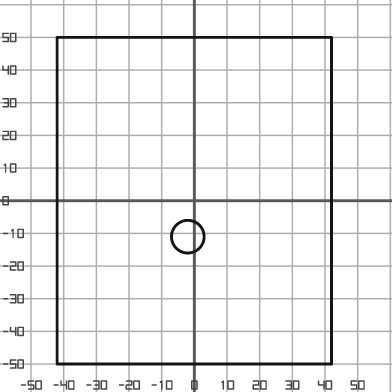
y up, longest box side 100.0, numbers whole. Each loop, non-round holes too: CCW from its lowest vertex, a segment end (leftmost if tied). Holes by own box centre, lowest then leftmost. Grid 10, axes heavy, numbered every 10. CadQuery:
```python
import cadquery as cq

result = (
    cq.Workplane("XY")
    .moveTo(-42.0, -50.0)
    .lineTo(42.0, -50.0)
    .lineTo(42.0, 50.0)
    .lineTo(-42.0, 50.0)
    .close()
    .moveTo(-2.0, -11.0)
    .circle(5.0)
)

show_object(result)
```